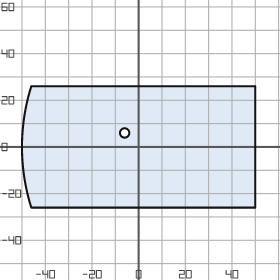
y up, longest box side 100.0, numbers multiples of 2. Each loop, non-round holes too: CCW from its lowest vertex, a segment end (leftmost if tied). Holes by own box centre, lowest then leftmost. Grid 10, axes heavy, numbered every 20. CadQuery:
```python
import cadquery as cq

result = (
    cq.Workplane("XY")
    .moveTo(-46.0, -26.0)
    .lineTo(50.0, -26.0)
    .lineTo(50.0, 26.0)
    .lineTo(-46.0, 26.0)
    .threePointArc((-50.0, 0.0), (-46.0, -26.0))
    .close()
    .moveTo(-6.0, 6.0)
    .circle(2.0)
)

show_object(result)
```